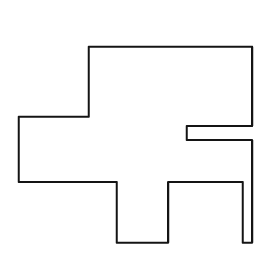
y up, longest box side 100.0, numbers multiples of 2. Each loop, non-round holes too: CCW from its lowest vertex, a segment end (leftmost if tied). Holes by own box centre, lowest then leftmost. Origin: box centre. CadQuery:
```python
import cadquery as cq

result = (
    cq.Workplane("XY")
    .moveTo(-8.0, -42.0)
    .lineTo(14.0, -42.0)
    .lineTo(14.0, -16.0)
    .lineTo(46.0, -16.0)
    .lineTo(46.0, -42.0)
    .lineTo(50.0, -42.0)
    .lineTo(50.0, 2.0)
    .lineTo(22.0, 2.0)
    .lineTo(22.0, 8.0)
    .lineTo(50.0, 8.0)
    .lineTo(50.0, 42.0)
    .lineTo(-20.0, 42.0)
    .lineTo(-20.0, 12.0)
    .lineTo(-50.0, 12.0)
    .lineTo(-50.0, -16.0)
    .lineTo(-8.0, -16.0)
    .close()
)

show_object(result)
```